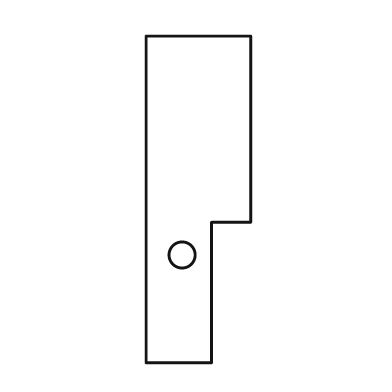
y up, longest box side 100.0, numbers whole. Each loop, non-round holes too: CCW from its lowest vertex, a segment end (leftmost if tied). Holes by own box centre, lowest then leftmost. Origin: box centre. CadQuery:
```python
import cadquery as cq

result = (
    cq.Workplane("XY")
    .moveTo(-16.0, -50.0)
    .lineTo(4.0, -50.0)
    .lineTo(4.0, -7.0)
    .lineTo(16.0, -7.0)
    .lineTo(16.0, 50.0)
    .lineTo(-16.0, 50.0)
    .close()
    .moveTo(-5.0, -17.0)
    .circle(4.0)
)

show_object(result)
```